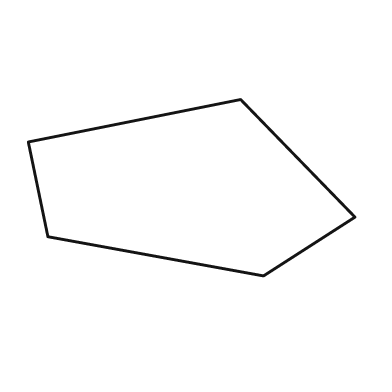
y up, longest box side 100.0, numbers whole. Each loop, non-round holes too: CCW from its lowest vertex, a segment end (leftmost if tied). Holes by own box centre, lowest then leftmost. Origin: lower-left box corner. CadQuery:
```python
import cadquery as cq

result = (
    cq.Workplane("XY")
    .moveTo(72.0, 0.0)
    .lineTo(100.0, 18.0)
    .lineTo(65.0, 54.0)
    .lineTo(0.0, 41.0)
    .lineTo(6.0, 12.0)
    .close()
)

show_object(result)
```